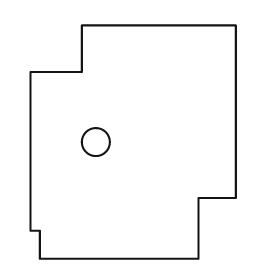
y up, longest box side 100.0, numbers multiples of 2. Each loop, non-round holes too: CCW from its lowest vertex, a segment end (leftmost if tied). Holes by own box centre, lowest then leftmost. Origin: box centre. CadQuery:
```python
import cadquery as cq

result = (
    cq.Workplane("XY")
    .moveTo(-40.0, -50.0)
    .lineTo(28.0, -50.0)
    .lineTo(28.0, -24.0)
    .lineTo(44.0, -24.0)
    .lineTo(44.0, 50.0)
    .lineTo(-22.0, 50.0)
    .lineTo(-22.0, 30.0)
    .lineTo(-44.0, 30.0)
    .lineTo(-44.0, -38.0)
    .lineTo(-40.0, -38.0)
    .close()
    .moveTo(-16.0, 0.0)
    .circle(6.0)
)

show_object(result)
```